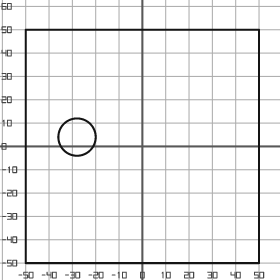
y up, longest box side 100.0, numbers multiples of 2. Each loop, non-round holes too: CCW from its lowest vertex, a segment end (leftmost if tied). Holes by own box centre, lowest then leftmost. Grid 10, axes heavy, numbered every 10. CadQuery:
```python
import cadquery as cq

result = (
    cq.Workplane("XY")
    .moveTo(-50.0, -50.0)
    .lineTo(50.0, -50.0)
    .lineTo(50.0, 50.0)
    .lineTo(-50.0, 50.0)
    .close()
    .moveTo(-28.0, 4.0)
    .circle(8.0)
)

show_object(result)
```